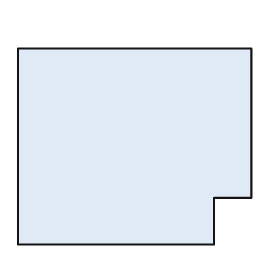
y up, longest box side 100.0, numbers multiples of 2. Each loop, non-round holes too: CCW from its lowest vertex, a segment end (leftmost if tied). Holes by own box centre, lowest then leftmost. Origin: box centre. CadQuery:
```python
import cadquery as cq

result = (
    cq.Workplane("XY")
    .moveTo(-50.0, -42.0)
    .lineTo(34.0, -42.0)
    .lineTo(34.0, -22.0)
    .lineTo(50.0, -22.0)
    .lineTo(50.0, 42.0)
    .lineTo(-50.0, 42.0)
    .close()
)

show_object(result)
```